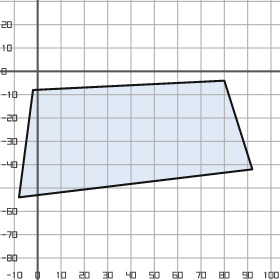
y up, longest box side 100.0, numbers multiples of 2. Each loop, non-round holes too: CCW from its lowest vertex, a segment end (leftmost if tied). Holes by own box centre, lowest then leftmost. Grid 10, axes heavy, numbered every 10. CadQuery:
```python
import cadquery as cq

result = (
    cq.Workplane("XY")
    .moveTo(-8.0, -54.0)
    .lineTo(92.0, -42.0)
    .lineTo(80.0, -4.0)
    .lineTo(-2.0, -8.0)
    .close()
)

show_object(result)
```